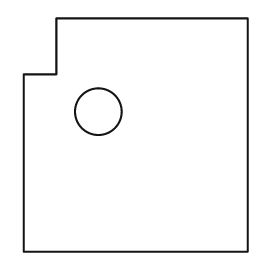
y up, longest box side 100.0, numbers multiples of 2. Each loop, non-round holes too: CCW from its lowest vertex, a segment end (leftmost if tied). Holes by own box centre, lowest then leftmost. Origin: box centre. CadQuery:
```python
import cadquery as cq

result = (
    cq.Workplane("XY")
    .moveTo(-48.0, -50.0)
    .lineTo(48.0, -50.0)
    .lineTo(48.0, 50.0)
    .lineTo(-34.0, 50.0)
    .lineTo(-34.0, 26.0)
    .lineTo(-48.0, 26.0)
    .close()
    .moveTo(-16.0, 10.0)
    .circle(10.0)
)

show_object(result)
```